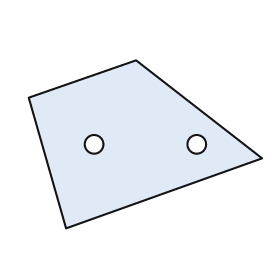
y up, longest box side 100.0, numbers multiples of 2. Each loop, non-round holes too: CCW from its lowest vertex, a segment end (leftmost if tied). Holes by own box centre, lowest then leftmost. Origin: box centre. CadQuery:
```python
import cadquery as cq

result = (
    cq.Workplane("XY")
    .moveTo(-34.0, -36.0)
    .lineTo(50.0, -6.0)
    .lineTo(-4.0, 36.0)
    .lineTo(-50.0, 20.0)
    .close()
    .moveTo(-22.0, 0.0)
    .circle(4.0)
    .moveTo(22.0, 0.0)
    .circle(4.0)
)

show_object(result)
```